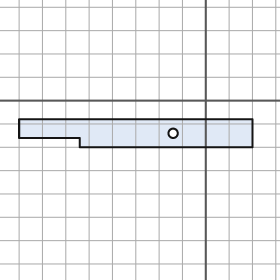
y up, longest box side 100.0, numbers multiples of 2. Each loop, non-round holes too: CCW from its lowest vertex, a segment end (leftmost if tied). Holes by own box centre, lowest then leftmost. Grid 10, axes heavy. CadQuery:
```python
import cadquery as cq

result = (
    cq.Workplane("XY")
    .moveTo(-54.0, -20.0)
    .lineTo(20.0, -20.0)
    .lineTo(20.0, -8.0)
    .lineTo(-80.0, -8.0)
    .lineTo(-80.0, -16.0)
    .lineTo(-54.0, -16.0)
    .close()
    .moveTo(-14.0, -14.0)
    .circle(2.0)
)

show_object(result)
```